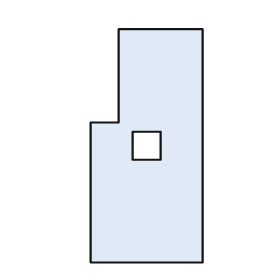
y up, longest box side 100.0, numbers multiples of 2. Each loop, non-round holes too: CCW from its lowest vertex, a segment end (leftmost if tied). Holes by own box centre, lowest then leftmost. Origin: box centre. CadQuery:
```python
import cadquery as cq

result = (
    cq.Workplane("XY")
    .moveTo(-24.0, -50.0)
    .lineTo(24.0, -50.0)
    .lineTo(24.0, 50.0)
    .lineTo(-12.0, 50.0)
    .lineTo(-12.0, 10.0)
    .lineTo(-24.0, 10.0)
    .close()
    .moveTo(-6.0, -6.0)
    .lineTo(6.0, -6.0)
    .lineTo(6.0, 6.0)
    .lineTo(-6.0, 6.0)
    .close()
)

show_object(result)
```